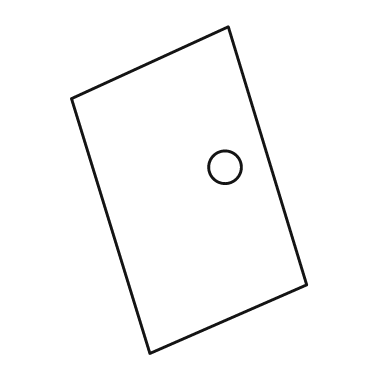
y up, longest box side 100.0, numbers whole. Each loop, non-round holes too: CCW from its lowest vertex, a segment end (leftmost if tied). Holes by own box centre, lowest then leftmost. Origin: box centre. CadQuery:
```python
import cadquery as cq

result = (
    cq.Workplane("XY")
    .moveTo(-12.0, -50.0)
    .lineTo(36.0, -29.0)
    .lineTo(12.0, 50.0)
    .lineTo(-36.0, 28.0)
    .close()
    .moveTo(11.0, 7.0)
    .circle(5.0)
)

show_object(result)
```